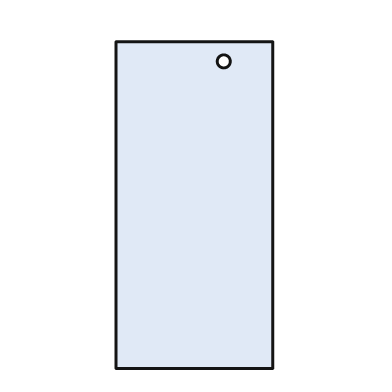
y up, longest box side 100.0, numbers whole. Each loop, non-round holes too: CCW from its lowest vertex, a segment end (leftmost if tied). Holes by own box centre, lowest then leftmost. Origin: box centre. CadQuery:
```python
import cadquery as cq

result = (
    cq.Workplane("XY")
    .moveTo(-24.0, -50.0)
    .lineTo(24.0, -50.0)
    .lineTo(24.0, 50.0)
    .lineTo(-24.0, 50.0)
    .close()
    .moveTo(9.0, 44.0)
    .circle(2.0)
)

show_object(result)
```